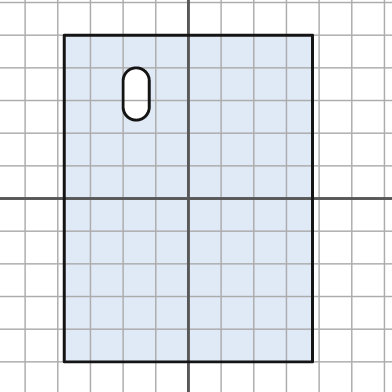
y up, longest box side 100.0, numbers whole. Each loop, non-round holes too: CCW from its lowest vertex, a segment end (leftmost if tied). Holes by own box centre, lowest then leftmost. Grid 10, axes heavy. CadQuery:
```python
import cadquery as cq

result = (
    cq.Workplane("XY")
    .moveTo(-38.0, -50.0)
    .lineTo(38.0, -50.0)
    .lineTo(38.0, 50.0)
    .lineTo(-38.0, 50.0)
    .close()
    .moveTo(-20.0, 28.0)
    .threePointArc((-16.0, 24.0), (-12.0, 28.0))
    .lineTo(-12.0, 36.0)
    .threePointArc((-16.0, 40.0), (-20.0, 36.0))
    .close()
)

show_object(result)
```